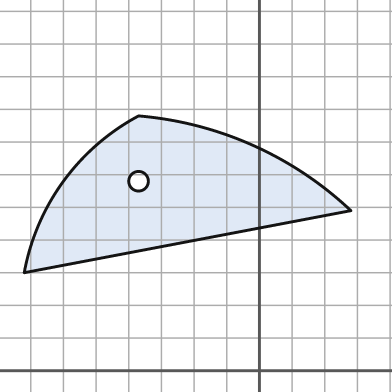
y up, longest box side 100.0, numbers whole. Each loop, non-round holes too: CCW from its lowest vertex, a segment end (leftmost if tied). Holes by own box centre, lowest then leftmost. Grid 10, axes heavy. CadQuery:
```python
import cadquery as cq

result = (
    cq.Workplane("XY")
    .moveTo(-72.0, 30.0)
    .lineTo(28.0, 49.0)
    .threePointArc((-2.0, 69.0), (-37.0, 78.0))
    .threePointArc((-60.0, 58.0), (-72.0, 30.0))
    .close()
    .moveTo(-37.0, 58.0)
    .circle(3.0)
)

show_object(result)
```